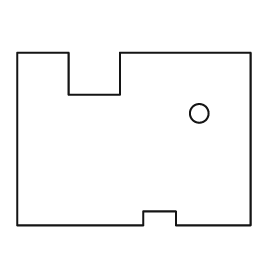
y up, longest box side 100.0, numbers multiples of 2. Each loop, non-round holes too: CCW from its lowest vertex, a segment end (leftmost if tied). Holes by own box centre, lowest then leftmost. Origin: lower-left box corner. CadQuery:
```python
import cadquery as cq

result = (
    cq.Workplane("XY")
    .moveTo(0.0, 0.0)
    .lineTo(54.0, 0.0)
    .lineTo(54.0, 6.0)
    .lineTo(68.0, 6.0)
    .lineTo(68.0, 0.0)
    .lineTo(100.0, 0.0)
    .lineTo(100.0, 74.0)
    .lineTo(44.0, 74.0)
    .lineTo(44.0, 56.0)
    .lineTo(22.0, 56.0)
    .lineTo(22.0, 74.0)
    .lineTo(0.0, 74.0)
    .close()
    .moveTo(78.0, 48.0)
    .circle(4.0)
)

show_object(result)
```